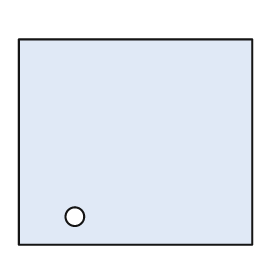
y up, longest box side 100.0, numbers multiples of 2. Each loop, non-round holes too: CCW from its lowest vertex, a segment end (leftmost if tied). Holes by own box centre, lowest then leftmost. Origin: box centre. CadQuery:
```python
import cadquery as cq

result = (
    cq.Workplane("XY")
    .moveTo(-50.0, -44.0)
    .lineTo(50.0, -44.0)
    .lineTo(50.0, 44.0)
    .lineTo(-50.0, 44.0)
    .close()
    .moveTo(-26.0, -32.0)
    .circle(4.0)
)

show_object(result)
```